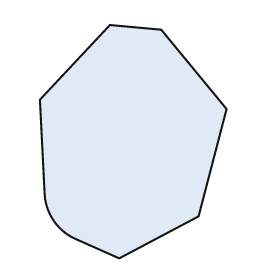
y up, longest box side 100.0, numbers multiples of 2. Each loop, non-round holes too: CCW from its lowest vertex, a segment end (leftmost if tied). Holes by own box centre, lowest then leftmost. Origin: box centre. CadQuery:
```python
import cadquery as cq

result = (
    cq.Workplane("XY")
    .moveTo(-6.0, -50.0)
    .lineTo(28.0, -32.0)
    .lineTo(40.0, 14.0)
    .lineTo(12.0, 48.0)
    .lineTo(-10.0, 50.0)
    .lineTo(-40.0, 18.0)
    .lineTo(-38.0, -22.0)
    .threePointArc((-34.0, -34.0), (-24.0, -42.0))
    .close()
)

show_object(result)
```